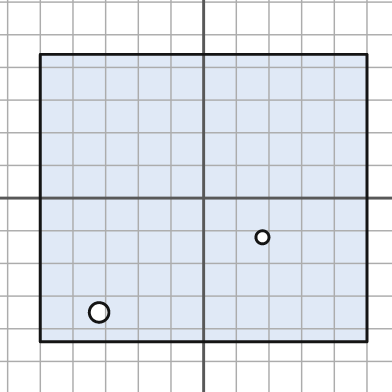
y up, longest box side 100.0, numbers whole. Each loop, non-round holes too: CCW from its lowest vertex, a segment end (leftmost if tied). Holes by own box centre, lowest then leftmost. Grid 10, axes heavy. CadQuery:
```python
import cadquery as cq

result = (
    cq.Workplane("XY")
    .moveTo(-50.0, -44.0)
    .lineTo(50.0, -44.0)
    .lineTo(50.0, 44.0)
    .lineTo(-50.0, 44.0)
    .close()
    .moveTo(-32.0, -35.0)
    .circle(3.0)
    .moveTo(18.0, -12.0)
    .circle(2.0)
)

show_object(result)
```